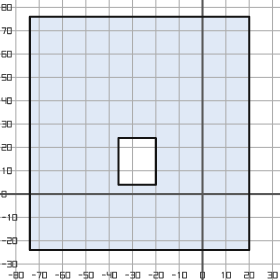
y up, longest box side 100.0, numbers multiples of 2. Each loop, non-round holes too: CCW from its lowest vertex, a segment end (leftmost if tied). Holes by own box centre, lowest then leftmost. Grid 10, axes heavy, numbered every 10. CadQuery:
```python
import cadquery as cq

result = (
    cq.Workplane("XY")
    .moveTo(-74.0, -24.0)
    .lineTo(20.0, -24.0)
    .lineTo(20.0, 76.0)
    .lineTo(-74.0, 76.0)
    .close()
    .moveTo(-36.0, 4.0)
    .lineTo(-20.0, 4.0)
    .lineTo(-20.0, 24.0)
    .lineTo(-36.0, 24.0)
    .close()
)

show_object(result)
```